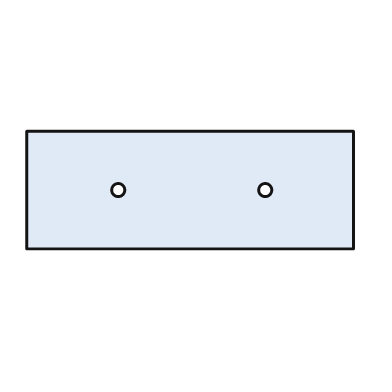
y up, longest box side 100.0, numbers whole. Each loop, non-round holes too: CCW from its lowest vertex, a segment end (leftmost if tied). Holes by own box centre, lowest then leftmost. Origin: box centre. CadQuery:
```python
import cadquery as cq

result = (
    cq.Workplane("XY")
    .moveTo(-50.0, -18.0)
    .lineTo(50.0, -18.0)
    .lineTo(50.0, 18.0)
    .lineTo(-50.0, 18.0)
    .close()
    .moveTo(-22.0, 0.0)
    .circle(2.0)
    .moveTo(23.0, 0.0)
    .circle(2.0)
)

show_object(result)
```